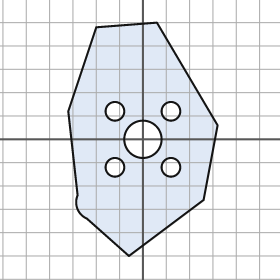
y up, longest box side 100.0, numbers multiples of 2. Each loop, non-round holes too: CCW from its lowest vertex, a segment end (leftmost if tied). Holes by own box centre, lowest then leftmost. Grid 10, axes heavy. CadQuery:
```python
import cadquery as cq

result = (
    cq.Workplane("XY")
    .moveTo(-6.0, -50.0)
    .lineTo(26.0, -26.0)
    .lineTo(32.0, 6.0)
    .lineTo(6.0, 50.0)
    .lineTo(-20.0, 48.0)
    .lineTo(-32.0, 12.0)
    .lineTo(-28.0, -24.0)
    .threePointArc((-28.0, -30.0), (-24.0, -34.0))
    .close()
    .moveTo(-12.0, -12.0)
    .circle(4.0)
    .moveTo(12.0, -12.0)
    .circle(4.0)
    .moveTo(0.0, 0.0)
    .circle(8.0)
    .moveTo(-12.0, 12.0)
    .circle(4.0)
    .moveTo(12.0, 12.0)
    .circle(4.0)
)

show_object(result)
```